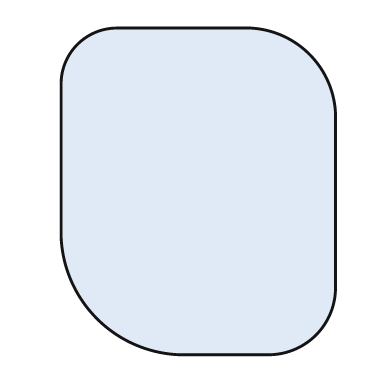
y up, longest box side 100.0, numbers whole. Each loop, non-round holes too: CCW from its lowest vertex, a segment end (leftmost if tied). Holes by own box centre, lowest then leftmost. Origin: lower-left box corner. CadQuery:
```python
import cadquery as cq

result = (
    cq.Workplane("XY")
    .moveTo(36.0, 0.0)
    .lineTo(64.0, 0.0)
    .threePointArc((78.0, 6.0), (84.0, 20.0))
    .lineTo(84.0, 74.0)
    .threePointArc((76.0, 92.0), (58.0, 100.0))
    .lineTo(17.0, 100.0)
    .threePointArc((5.0, 95.0), (0.0, 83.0))
    .lineTo(0.0, 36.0)
    .threePointArc((11.0, 11.0), (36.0, 0.0))
    .close()
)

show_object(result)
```